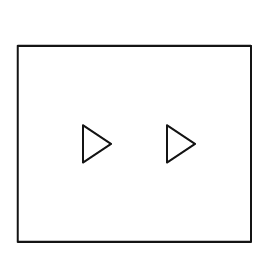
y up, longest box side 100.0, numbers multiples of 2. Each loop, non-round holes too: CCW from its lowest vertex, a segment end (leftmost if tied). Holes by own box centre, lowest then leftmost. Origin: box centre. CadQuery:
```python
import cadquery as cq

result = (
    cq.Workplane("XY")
    .moveTo(-50.0, -42.0)
    .lineTo(50.0, -42.0)
    .lineTo(50.0, 42.0)
    .lineTo(-50.0, 42.0)
    .close()
    .moveTo(-22.0, -8.0)
    .lineTo(-10.0, 0.0)
    .lineTo(-22.0, 8.0)
    .close()
    .moveTo(14.0, -8.0)
    .lineTo(26.0, 0.0)
    .lineTo(14.0, 8.0)
    .close()
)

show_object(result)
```